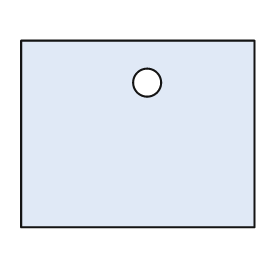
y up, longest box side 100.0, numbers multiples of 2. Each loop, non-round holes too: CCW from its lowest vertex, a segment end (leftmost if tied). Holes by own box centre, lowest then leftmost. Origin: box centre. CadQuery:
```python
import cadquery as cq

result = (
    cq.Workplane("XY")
    .moveTo(-50.0, -40.0)
    .lineTo(50.0, -40.0)
    .lineTo(50.0, 40.0)
    .lineTo(-50.0, 40.0)
    .close()
    .moveTo(4.0, 22.0)
    .circle(6.0)
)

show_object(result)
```